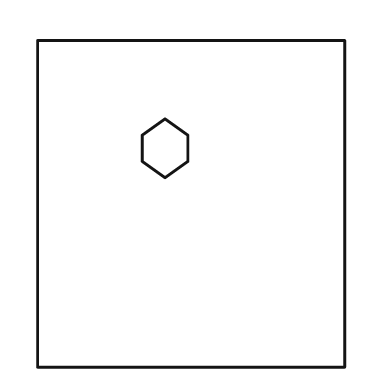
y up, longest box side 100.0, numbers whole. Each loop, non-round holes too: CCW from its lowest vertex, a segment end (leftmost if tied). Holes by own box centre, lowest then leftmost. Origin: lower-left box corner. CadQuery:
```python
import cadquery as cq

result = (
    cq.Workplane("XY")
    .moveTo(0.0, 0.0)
    .lineTo(94.0, 0.0)
    .lineTo(94.0, 100.0)
    .lineTo(0.0, 100.0)
    .close()
    .moveTo(39.0, 58.0)
    .lineTo(46.0, 63.0)
    .lineTo(46.0, 71.0)
    .lineTo(39.0, 76.0)
    .lineTo(32.0, 71.0)
    .lineTo(32.0, 63.0)
    .close()
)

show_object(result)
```